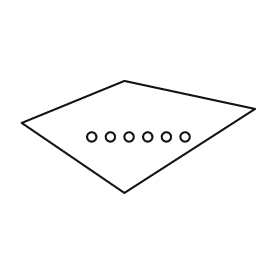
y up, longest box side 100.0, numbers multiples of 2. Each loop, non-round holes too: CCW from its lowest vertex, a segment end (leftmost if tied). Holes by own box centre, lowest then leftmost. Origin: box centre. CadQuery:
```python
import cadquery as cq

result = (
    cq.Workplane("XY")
    .moveTo(-6.0, -24.0)
    .lineTo(50.0, 12.0)
    .lineTo(-6.0, 24.0)
    .lineTo(-50.0, 6.0)
    .close()
    .moveTo(-20.0, 0.0)
    .circle(2.0)
    .moveTo(-12.0, 0.0)
    .circle(2.0)
    .moveTo(-4.0, 0.0)
    .circle(2.0)
    .moveTo(4.0, 0.0)
    .circle(2.0)
    .moveTo(12.0, 0.0)
    .circle(2.0)
    .moveTo(20.0, 0.0)
    .circle(2.0)
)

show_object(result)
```